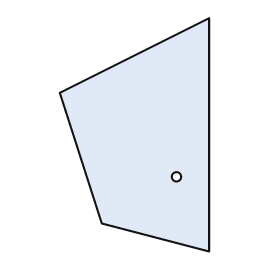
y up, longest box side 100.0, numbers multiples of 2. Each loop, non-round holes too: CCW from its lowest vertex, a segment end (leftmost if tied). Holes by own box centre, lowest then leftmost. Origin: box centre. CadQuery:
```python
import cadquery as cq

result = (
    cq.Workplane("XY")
    .moveTo(32.0, -50.0)
    .lineTo(32.0, 50.0)
    .lineTo(-32.0, 18.0)
    .lineTo(-14.0, -38.0)
    .close()
    .moveTo(18.0, -18.0)
    .circle(2.0)
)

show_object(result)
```